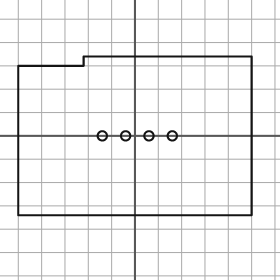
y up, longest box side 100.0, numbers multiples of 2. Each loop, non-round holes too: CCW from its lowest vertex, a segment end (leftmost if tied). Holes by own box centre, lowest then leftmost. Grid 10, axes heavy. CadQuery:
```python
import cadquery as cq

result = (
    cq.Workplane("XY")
    .moveTo(-50.0, -34.0)
    .lineTo(50.0, -34.0)
    .lineTo(50.0, 34.0)
    .lineTo(-22.0, 34.0)
    .lineTo(-22.0, 30.0)
    .lineTo(-50.0, 30.0)
    .close()
    .moveTo(-14.0, 0.0)
    .circle(2.0)
    .moveTo(-4.0, 0.0)
    .circle(2.0)
    .moveTo(6.0, 0.0)
    .circle(2.0)
    .moveTo(16.0, 0.0)
    .circle(2.0)
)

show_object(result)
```